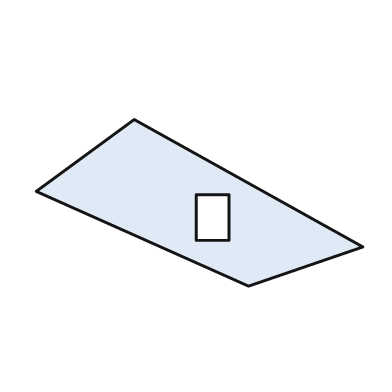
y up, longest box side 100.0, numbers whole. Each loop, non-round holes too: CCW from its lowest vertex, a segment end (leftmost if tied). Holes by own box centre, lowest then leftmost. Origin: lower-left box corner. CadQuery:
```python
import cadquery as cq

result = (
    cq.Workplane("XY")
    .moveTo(65.0, 0.0)
    .lineTo(100.0, 12.0)
    .lineTo(30.0, 51.0)
    .lineTo(0.0, 29.0)
    .close()
    .moveTo(49.0, 14.0)
    .lineTo(59.0, 14.0)
    .lineTo(59.0, 28.0)
    .lineTo(49.0, 28.0)
    .close()
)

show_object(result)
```